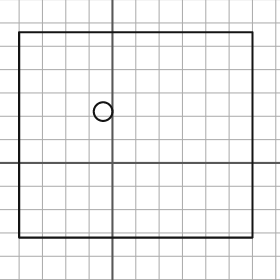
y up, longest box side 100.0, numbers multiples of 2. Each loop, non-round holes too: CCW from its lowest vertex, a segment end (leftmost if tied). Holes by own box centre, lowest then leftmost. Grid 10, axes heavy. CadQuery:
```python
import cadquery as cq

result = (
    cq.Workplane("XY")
    .moveTo(-40.0, -32.0)
    .lineTo(60.0, -32.0)
    .lineTo(60.0, 56.0)
    .lineTo(-40.0, 56.0)
    .close()
    .moveTo(-4.0, 22.0)
    .circle(4.0)
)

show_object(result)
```